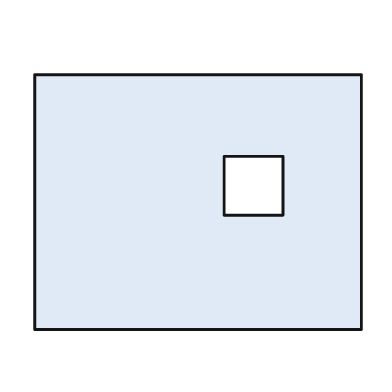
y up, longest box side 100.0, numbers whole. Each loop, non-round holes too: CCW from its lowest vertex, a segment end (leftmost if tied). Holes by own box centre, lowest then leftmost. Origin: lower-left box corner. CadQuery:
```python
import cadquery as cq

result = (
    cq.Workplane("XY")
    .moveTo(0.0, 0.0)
    .lineTo(100.0, 0.0)
    .lineTo(100.0, 78.0)
    .lineTo(0.0, 78.0)
    .close()
    .moveTo(58.0, 35.0)
    .lineTo(76.0, 35.0)
    .lineTo(76.0, 53.0)
    .lineTo(58.0, 53.0)
    .close()
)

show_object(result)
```